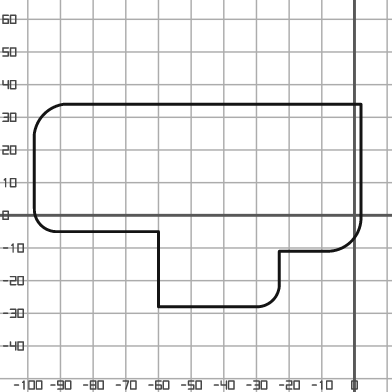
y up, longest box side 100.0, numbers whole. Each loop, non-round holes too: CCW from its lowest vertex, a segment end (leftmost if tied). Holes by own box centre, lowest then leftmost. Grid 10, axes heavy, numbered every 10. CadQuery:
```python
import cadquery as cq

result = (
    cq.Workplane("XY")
    .moveTo(-60.0, -28.0)
    .lineTo(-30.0, -28.0)
    .threePointArc((-25.0, -26.0), (-23.0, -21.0))
    .lineTo(-23.0, -11.0)
    .lineTo(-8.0, -11.0)
    .threePointArc((-1.0, -8.0), (2.0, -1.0))
    .lineTo(2.0, 34.0)
    .lineTo(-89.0, 34.0)
    .threePointArc((-95.0, 31.0), (-98.0, 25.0))
    .lineTo(-98.0, 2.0)
    .threePointArc((-96.0, -3.0), (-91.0, -5.0))
    .lineTo(-60.0, -5.0)
    .close()
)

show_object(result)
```